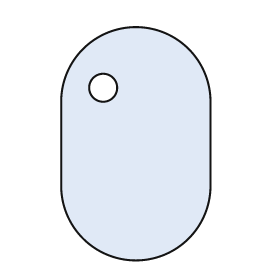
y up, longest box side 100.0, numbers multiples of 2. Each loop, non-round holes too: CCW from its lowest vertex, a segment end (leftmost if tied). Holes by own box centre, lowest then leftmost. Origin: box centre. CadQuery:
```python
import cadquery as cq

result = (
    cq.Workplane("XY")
    .moveTo(-32.0, -18.0)
    .threePointArc((0.0, -50.0), (32.0, -18.0))
    .lineTo(32.0, 18.0)
    .threePointArc((0.0, 50.0), (-32.0, 18.0))
    .close()
    .moveTo(-14.0, 24.0)
    .circle(6.0)
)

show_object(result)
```